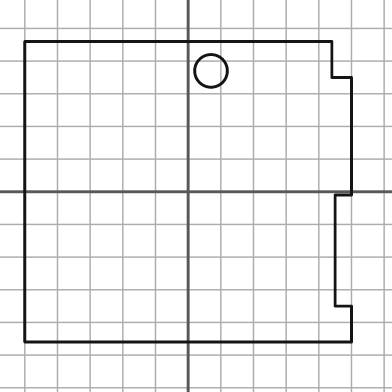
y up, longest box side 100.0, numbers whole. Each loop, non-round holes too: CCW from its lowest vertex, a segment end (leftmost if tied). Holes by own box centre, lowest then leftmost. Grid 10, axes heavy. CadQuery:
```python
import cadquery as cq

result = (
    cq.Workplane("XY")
    .moveTo(-50.0, -46.0)
    .lineTo(50.0, -46.0)
    .lineTo(50.0, -35.0)
    .lineTo(45.0, -35.0)
    .lineTo(45.0, -1.0)
    .lineTo(50.0, -1.0)
    .lineTo(50.0, 35.0)
    .lineTo(44.0, 35.0)
    .lineTo(44.0, 46.0)
    .lineTo(-50.0, 46.0)
    .close()
    .moveTo(7.0, 37.0)
    .circle(5.0)
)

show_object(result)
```